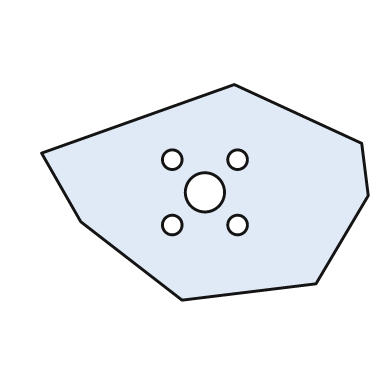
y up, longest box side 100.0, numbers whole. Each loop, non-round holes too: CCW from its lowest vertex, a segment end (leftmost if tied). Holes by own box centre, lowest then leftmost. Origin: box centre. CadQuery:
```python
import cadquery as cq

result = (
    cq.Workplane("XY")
    .moveTo(-7.0, -33.0)
    .lineTo(34.0, -28.0)
    .lineTo(50.0, -1.0)
    .lineTo(48.0, 15.0)
    .lineTo(9.0, 33.0)
    .lineTo(-50.0, 12.0)
    .lineTo(-38.0, -9.0)
    .close()
    .moveTo(-10.0, -10.0)
    .circle(3.0)
    .moveTo(10.0, -10.0)
    .circle(3.0)
    .moveTo(0.0, 0.0)
    .circle(6.0)
    .moveTo(-10.0, 10.0)
    .circle(3.0)
    .moveTo(10.0, 10.0)
    .circle(3.0)
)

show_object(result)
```